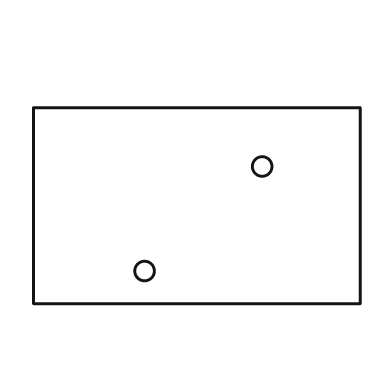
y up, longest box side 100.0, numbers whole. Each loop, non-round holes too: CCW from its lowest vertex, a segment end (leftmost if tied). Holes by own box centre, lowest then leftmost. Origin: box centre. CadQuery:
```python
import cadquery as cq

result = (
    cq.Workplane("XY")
    .moveTo(-50.0, -30.0)
    .lineTo(50.0, -30.0)
    .lineTo(50.0, 30.0)
    .lineTo(-50.0, 30.0)
    .close()
    .moveTo(-16.0, -20.0)
    .circle(3.0)
    .moveTo(20.0, 12.0)
    .circle(3.0)
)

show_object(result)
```